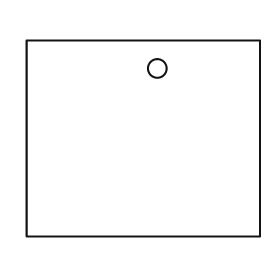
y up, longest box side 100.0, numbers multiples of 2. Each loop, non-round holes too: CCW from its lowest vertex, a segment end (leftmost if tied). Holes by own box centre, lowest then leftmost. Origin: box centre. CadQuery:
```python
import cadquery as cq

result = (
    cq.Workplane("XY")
    .moveTo(-50.0, -42.0)
    .lineTo(50.0, -42.0)
    .lineTo(50.0, 42.0)
    .lineTo(-50.0, 42.0)
    .close()
    .moveTo(6.0, 30.0)
    .circle(4.0)
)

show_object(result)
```